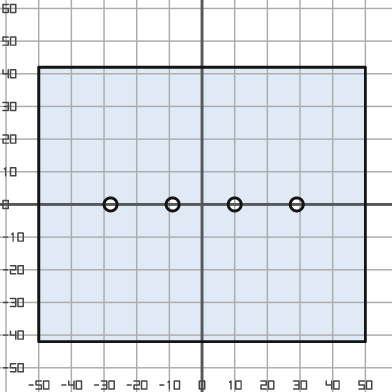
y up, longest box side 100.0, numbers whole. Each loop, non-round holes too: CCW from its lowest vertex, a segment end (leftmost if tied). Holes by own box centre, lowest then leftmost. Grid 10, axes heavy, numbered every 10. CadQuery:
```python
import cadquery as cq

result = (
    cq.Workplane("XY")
    .moveTo(-50.0, -42.0)
    .lineTo(50.0, -42.0)
    .lineTo(50.0, 42.0)
    .lineTo(-50.0, 42.0)
    .close()
    .moveTo(-28.0, 0.0)
    .circle(2.0)
    .moveTo(-9.0, 0.0)
    .circle(2.0)
    .moveTo(10.0, 0.0)
    .circle(2.0)
    .moveTo(29.0, 0.0)
    .circle(2.0)
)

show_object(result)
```